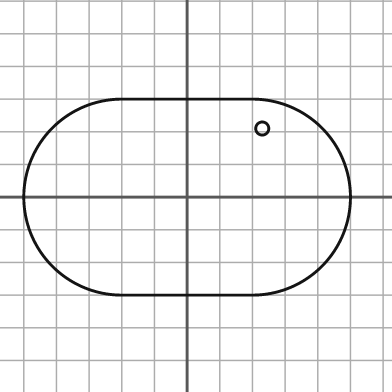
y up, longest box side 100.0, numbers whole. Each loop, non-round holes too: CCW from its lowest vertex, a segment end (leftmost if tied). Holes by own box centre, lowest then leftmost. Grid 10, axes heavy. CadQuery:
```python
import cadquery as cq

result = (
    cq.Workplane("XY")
    .moveTo(-20.0, -30.0)
    .lineTo(20.0, -30.0)
    .threePointArc((50.0, 0.0), (20.0, 30.0))
    .lineTo(-20.0, 30.0)
    .threePointArc((-50.0, 0.0), (-20.0, -30.0))
    .close()
    .moveTo(23.0, 21.0)
    .circle(2.0)
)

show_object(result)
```